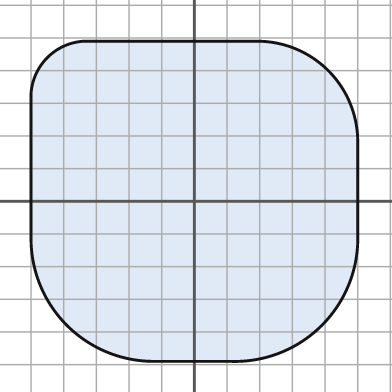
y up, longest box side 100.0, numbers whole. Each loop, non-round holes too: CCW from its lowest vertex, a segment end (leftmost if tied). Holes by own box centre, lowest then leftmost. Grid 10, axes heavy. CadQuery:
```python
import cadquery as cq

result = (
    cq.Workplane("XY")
    .moveTo(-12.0, -49.0)
    .lineTo(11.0, -49.0)
    .threePointArc((39.0, -38.0), (50.0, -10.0))
    .lineTo(50.0, 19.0)
    .threePointArc((41.0, 40.0), (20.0, 49.0))
    .lineTo(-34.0, 49.0)
    .threePointArc((-45.0, 44.0), (-50.0, 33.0))
    .lineTo(-50.0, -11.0)
    .threePointArc((-39.0, -38.0), (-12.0, -49.0))
    .close()
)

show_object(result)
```